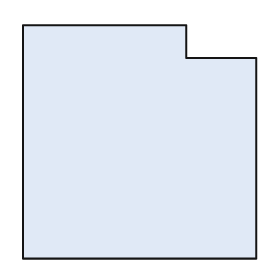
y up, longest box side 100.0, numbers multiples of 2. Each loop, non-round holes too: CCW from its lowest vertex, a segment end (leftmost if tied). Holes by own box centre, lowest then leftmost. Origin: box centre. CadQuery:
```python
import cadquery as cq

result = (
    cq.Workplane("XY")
    .moveTo(-50.0, -50.0)
    .lineTo(50.0, -50.0)
    .lineTo(50.0, 36.0)
    .lineTo(20.0, 36.0)
    .lineTo(20.0, 50.0)
    .lineTo(-50.0, 50.0)
    .close()
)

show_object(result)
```